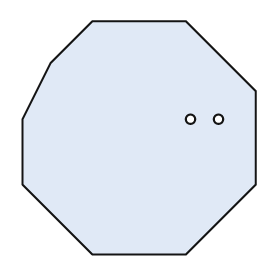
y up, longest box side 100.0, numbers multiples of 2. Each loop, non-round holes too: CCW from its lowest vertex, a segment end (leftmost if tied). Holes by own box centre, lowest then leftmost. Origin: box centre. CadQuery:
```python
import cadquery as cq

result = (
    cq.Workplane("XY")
    .moveTo(-20.0, -50.0)
    .lineTo(20.0, -50.0)
    .lineTo(50.0, -20.0)
    .lineTo(50.0, 20.0)
    .lineTo(20.0, 50.0)
    .lineTo(-20.0, 50.0)
    .lineTo(-38.0, 32.0)
    .lineTo(-50.0, 8.0)
    .lineTo(-50.0, -20.0)
    .close()
    .moveTo(22.0, 8.0)
    .circle(2.0)
    .moveTo(34.0, 8.0)
    .circle(2.0)
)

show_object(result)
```